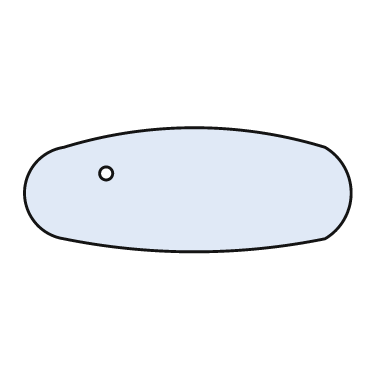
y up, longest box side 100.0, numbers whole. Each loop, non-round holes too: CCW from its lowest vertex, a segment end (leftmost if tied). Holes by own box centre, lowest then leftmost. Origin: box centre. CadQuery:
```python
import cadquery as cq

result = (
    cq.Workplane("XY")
    .moveTo(-38.0, -15.0)
    .threePointArc((2.0, -19.0), (42.0, -15.0))
    .threePointArc((50.0, -1.0), (42.0, 13.0))
    .threePointArc((2.0, 19.0), (-38.0, 13.0))
    .threePointArc((-50.0, -1.0), (-38.0, -15.0))
    .close()
    .moveTo(-25.0, 5.0)
    .circle(2.0)
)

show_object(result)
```